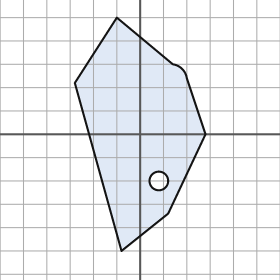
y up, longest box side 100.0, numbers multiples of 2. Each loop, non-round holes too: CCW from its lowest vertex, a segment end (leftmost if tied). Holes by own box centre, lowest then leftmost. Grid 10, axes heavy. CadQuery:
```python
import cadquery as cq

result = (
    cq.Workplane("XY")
    .moveTo(-8.0, -50.0)
    .lineTo(12.0, -34.0)
    .lineTo(28.0, 0.0)
    .lineTo(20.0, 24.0)
    .threePointArc((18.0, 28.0), (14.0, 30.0))
    .lineTo(-10.0, 50.0)
    .lineTo(-28.0, 22.0)
    .close()
    .moveTo(8.0, -20.0)
    .circle(4.0)
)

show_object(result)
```